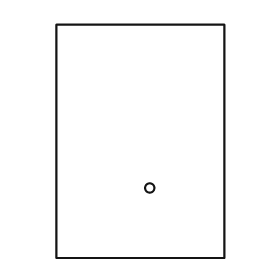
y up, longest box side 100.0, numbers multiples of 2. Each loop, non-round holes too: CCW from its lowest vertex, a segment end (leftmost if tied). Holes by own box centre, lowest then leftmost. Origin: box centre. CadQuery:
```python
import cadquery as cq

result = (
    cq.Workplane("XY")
    .moveTo(-36.0, -50.0)
    .lineTo(36.0, -50.0)
    .lineTo(36.0, 50.0)
    .lineTo(-36.0, 50.0)
    .close()
    .moveTo(4.0, -20.0)
    .circle(2.0)
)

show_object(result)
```